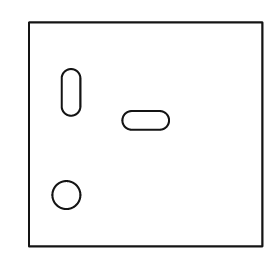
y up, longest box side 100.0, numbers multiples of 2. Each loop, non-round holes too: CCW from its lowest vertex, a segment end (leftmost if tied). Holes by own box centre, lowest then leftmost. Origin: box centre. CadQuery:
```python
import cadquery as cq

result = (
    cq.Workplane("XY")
    .moveTo(-50.0, -48.0)
    .lineTo(50.0, -48.0)
    .lineTo(50.0, 48.0)
    .lineTo(-50.0, 48.0)
    .close()
    .moveTo(-34.0, -26.0)
    .circle(6.0)
    .moveTo(-6.0, 2.0)
    .lineTo(6.0, 2.0)
    .threePointArc((10.0, 6.0), (6.0, 10.0))
    .lineTo(-6.0, 10.0)
    .threePointArc((-10.0, 6.0), (-6.0, 2.0))
    .close()
    .moveTo(-36.0, 12.0)
    .threePointArc((-32.0, 8.0), (-28.0, 12.0))
    .lineTo(-28.0, 24.0)
    .threePointArc((-32.0, 28.0), (-36.0, 24.0))
    .close()
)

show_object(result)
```